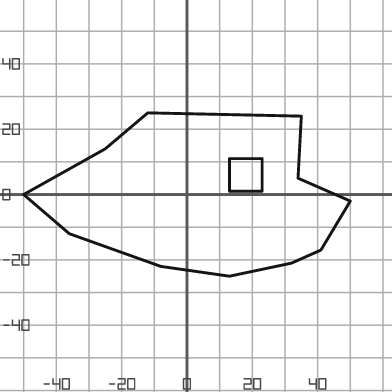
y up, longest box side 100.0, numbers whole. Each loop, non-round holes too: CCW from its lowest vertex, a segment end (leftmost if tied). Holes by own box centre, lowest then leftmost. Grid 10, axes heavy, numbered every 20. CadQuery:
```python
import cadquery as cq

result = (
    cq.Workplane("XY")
    .moveTo(13.0, -25.0)
    .lineTo(32.0, -21.0)
    .lineTo(41.0, -17.0)
    .lineTo(50.0, -2.0)
    .lineTo(34.0, 5.0)
    .lineTo(35.0, 24.0)
    .lineTo(-12.0, 25.0)
    .lineTo(-25.0, 14.0)
    .lineTo(-50.0, 0.0)
    .lineTo(-36.0, -12.0)
    .lineTo(-8.0, -22.0)
    .close()
    .moveTo(13.0, 1.0)
    .lineTo(23.0, 1.0)
    .lineTo(23.0, 11.0)
    .lineTo(13.0, 11.0)
    .close()
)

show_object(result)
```